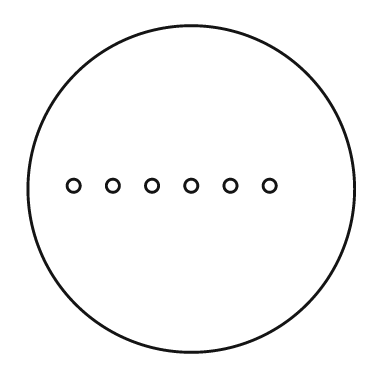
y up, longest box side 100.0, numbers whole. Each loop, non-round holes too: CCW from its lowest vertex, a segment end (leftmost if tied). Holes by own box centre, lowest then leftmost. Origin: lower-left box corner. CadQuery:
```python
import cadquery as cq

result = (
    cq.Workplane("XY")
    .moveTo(50.0, 50.0)
    .circle(50.0)
    .moveTo(14.0, 51.0)
    .circle(2.0)
    .moveTo(26.0, 51.0)
    .circle(2.0)
    .moveTo(38.0, 51.0)
    .circle(2.0)
    .moveTo(50.0, 51.0)
    .circle(2.0)
    .moveTo(62.0, 51.0)
    .circle(2.0)
    .moveTo(74.0, 51.0)
    .circle(2.0)
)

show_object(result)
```